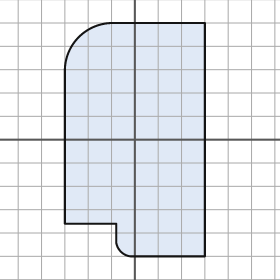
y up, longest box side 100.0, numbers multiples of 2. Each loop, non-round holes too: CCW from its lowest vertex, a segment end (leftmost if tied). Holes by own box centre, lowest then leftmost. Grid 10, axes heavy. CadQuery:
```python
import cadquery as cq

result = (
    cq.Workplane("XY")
    .moveTo(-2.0, -50.0)
    .lineTo(30.0, -50.0)
    .lineTo(30.0, 50.0)
    .lineTo(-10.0, 50.0)
    .threePointArc((-24.0, 44.0), (-30.0, 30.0))
    .lineTo(-30.0, -36.0)
    .lineTo(-8.0, -36.0)
    .lineTo(-8.0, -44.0)
    .threePointArc((-6.0, -48.0), (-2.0, -50.0))
    .close()
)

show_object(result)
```